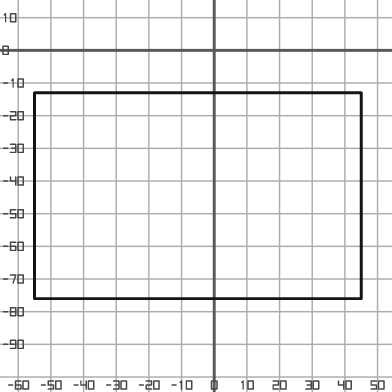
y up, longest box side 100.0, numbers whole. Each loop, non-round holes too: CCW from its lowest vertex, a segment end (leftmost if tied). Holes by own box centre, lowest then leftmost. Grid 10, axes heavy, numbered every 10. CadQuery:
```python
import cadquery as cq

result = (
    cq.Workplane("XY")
    .moveTo(-55.0, -76.0)
    .lineTo(45.0, -76.0)
    .lineTo(45.0, -13.0)
    .lineTo(-55.0, -13.0)
    .close()
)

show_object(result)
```